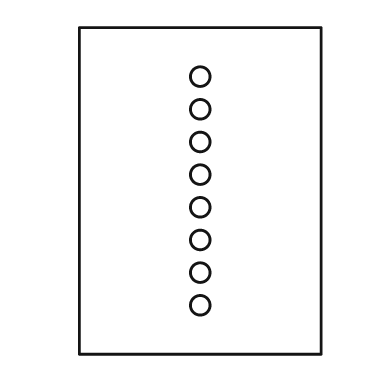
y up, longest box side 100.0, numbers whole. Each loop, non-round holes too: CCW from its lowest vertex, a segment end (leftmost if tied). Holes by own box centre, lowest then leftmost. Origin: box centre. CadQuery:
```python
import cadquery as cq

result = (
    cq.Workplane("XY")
    .moveTo(-37.0, -50.0)
    .lineTo(37.0, -50.0)
    .lineTo(37.0, 50.0)
    .lineTo(-37.0, 50.0)
    .close()
    .moveTo(0.0, -35.0)
    .circle(3.0)
    .moveTo(0.0, -25.0)
    .circle(3.0)
    .moveTo(0.0, -15.0)
    .circle(3.0)
    .moveTo(0.0, -5.0)
    .circle(3.0)
    .moveTo(0.0, 5.0)
    .circle(3.0)
    .moveTo(0.0, 15.0)
    .circle(3.0)
    .moveTo(0.0, 25.0)
    .circle(3.0)
    .moveTo(0.0, 35.0)
    .circle(3.0)
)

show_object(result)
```